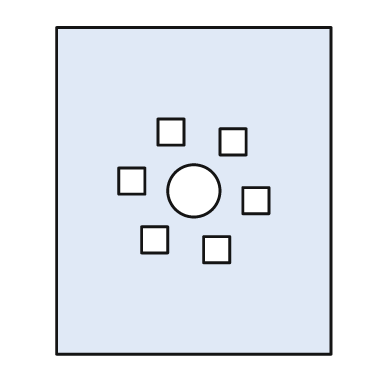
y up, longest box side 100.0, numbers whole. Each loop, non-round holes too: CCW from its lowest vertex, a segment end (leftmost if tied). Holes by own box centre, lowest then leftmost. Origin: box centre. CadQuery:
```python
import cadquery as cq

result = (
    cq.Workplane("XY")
    .moveTo(-42.0, -50.0)
    .lineTo(42.0, -50.0)
    .lineTo(42.0, 50.0)
    .lineTo(-42.0, 50.0)
    .close()
    .moveTo(3.0, -22.0)
    .lineTo(11.0, -22.0)
    .lineTo(11.0, -14.0)
    .lineTo(3.0, -14.0)
    .close()
    .moveTo(-16.0, -19.0)
    .lineTo(-8.0, -19.0)
    .lineTo(-8.0, -11.0)
    .lineTo(-16.0, -11.0)
    .close()
    .moveTo(15.0, -7.0)
    .lineTo(23.0, -7.0)
    .lineTo(23.0, 1.0)
    .lineTo(15.0, 1.0)
    .close()
    .moveTo(0.0, 0.0)
    .circle(8.0)
    .moveTo(-23.0, -1.0)
    .lineTo(-15.0, -1.0)
    .lineTo(-15.0, 7.0)
    .lineTo(-23.0, 7.0)
    .close()
    .moveTo(8.0, 11.0)
    .lineTo(16.0, 11.0)
    .lineTo(16.0, 19.0)
    .lineTo(8.0, 19.0)
    .close()
    .moveTo(-11.0, 14.0)
    .lineTo(-3.0, 14.0)
    .lineTo(-3.0, 22.0)
    .lineTo(-11.0, 22.0)
    .close()
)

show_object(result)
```